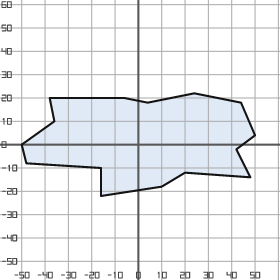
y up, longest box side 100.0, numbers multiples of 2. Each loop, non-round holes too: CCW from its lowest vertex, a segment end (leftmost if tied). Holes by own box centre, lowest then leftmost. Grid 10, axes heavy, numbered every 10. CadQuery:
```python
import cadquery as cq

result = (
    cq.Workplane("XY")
    .moveTo(-16.0, -22.0)
    .lineTo(10.0, -18.0)
    .lineTo(20.0, -12.0)
    .lineTo(48.0, -14.0)
    .lineTo(42.0, -2.0)
    .lineTo(50.0, 4.0)
    .lineTo(44.0, 18.0)
    .lineTo(24.0, 22.0)
    .lineTo(4.0, 18.0)
    .lineTo(-6.0, 20.0)
    .lineTo(-38.0, 20.0)
    .lineTo(-36.0, 10.0)
    .lineTo(-50.0, 0.0)
    .lineTo(-48.0, -8.0)
    .lineTo(-16.0, -10.0)
    .close()
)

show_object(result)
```